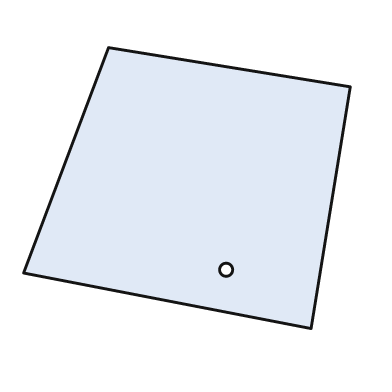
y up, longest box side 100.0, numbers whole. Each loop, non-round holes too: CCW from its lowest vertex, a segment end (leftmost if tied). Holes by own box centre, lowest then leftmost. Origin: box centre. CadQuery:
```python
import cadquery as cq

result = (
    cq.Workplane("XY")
    .moveTo(38.0, -43.0)
    .lineTo(50.0, 31.0)
    .lineTo(-24.0, 43.0)
    .lineTo(-50.0, -26.0)
    .close()
    .moveTo(12.0, -25.0)
    .circle(2.0)
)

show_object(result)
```